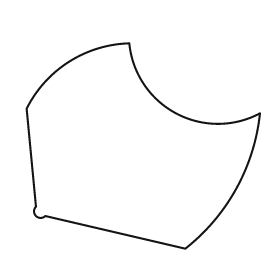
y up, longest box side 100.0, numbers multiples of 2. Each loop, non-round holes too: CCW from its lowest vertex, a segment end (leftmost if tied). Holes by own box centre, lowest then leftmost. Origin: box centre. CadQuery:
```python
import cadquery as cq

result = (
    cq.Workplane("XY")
    .moveTo(18.0, -44.0)
    .threePointArc((40.0, -18.0), (50.0, 14.0))
    .threePointArc((14.0, 14.0), (-6.0, 44.0))
    .threePointArc((-32.0, 36.0), (-50.0, 16.0))
    .lineTo(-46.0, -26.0)
    .threePointArc((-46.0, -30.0), (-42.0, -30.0))
    .close()
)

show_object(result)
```